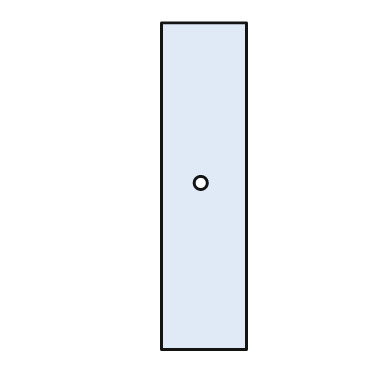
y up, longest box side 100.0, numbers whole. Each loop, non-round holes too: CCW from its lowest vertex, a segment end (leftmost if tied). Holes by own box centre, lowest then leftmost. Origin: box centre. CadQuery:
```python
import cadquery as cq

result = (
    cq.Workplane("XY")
    .moveTo(-13.0, -50.0)
    .lineTo(13.0, -50.0)
    .lineTo(13.0, 50.0)
    .lineTo(-13.0, 50.0)
    .close()
    .moveTo(-1.0, 1.0)
    .circle(2.0)
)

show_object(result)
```